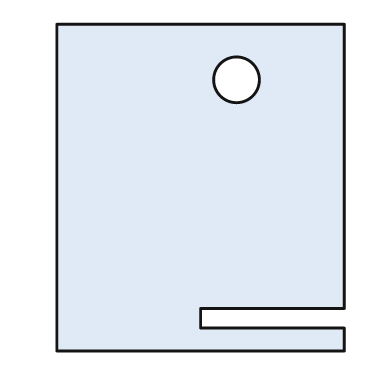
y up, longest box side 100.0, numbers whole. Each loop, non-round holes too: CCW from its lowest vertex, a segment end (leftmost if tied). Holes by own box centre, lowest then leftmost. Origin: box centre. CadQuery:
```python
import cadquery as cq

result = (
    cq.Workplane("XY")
    .moveTo(-44.0, -50.0)
    .lineTo(44.0, -50.0)
    .lineTo(44.0, -43.0)
    .lineTo(0.0, -43.0)
    .lineTo(0.0, -37.0)
    .lineTo(44.0, -37.0)
    .lineTo(44.0, 50.0)
    .lineTo(-44.0, 50.0)
    .close()
    .moveTo(11.0, 33.0)
    .circle(7.0)
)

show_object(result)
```